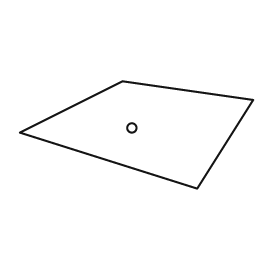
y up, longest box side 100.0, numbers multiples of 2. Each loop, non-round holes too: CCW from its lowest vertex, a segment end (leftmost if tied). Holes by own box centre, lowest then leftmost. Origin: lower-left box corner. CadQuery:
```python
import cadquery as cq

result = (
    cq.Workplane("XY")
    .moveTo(76.0, 0.0)
    .lineTo(100.0, 38.0)
    .lineTo(44.0, 46.0)
    .lineTo(0.0, 24.0)
    .close()
    .moveTo(48.0, 26.0)
    .circle(2.0)
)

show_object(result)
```